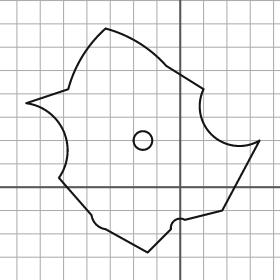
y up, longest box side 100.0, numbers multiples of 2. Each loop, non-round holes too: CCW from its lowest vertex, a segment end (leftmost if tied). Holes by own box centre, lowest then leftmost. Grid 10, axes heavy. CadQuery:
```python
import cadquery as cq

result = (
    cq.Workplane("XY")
    .moveTo(-14.0, -28.0)
    .lineTo(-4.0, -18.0)
    .threePointArc((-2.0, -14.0), (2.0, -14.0))
    .lineTo(18.0, -10.0)
    .lineTo(34.0, 20.0)
    .threePointArc((14.0, 22.0), (10.0, 42.0))
    .lineTo(-6.0, 52.0)
    .threePointArc((-18.0, 62.0), (-32.0, 68.0))
    .threePointArc((-42.0, 56.0), (-48.0, 42.0))
    .lineTo(-66.0, 36.0)
    .threePointArc((-50.0, 24.0), (-52.0, 4.0))
    .lineTo(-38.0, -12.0)
    .threePointArc((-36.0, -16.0), (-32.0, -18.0))
    .close()
    .moveTo(-16.0, 20.0)
    .circle(4.0)
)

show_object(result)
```